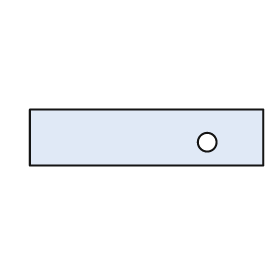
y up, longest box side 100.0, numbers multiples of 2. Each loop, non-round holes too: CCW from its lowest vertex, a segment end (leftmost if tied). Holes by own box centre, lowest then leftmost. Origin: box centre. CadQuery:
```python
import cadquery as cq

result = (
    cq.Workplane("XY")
    .moveTo(-50.0, -12.0)
    .lineTo(50.0, -12.0)
    .lineTo(50.0, 12.0)
    .lineTo(-50.0, 12.0)
    .close()
    .moveTo(26.0, -2.0)
    .circle(4.0)
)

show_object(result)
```